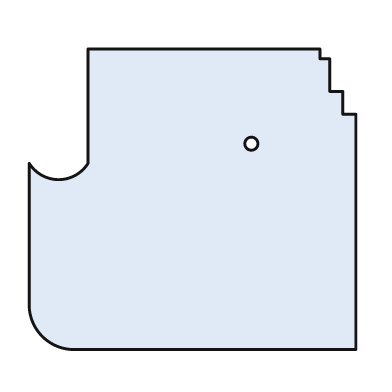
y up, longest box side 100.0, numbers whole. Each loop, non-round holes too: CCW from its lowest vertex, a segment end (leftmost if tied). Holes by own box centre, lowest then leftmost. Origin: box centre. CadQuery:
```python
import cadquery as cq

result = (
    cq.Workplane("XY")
    .moveTo(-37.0, -46.0)
    .lineTo(50.0, -46.0)
    .lineTo(50.0, 26.0)
    .lineTo(46.0, 26.0)
    .lineTo(46.0, 33.0)
    .lineTo(42.0, 33.0)
    .lineTo(42.0, 43.0)
    .lineTo(39.0, 43.0)
    .lineTo(39.0, 46.0)
    .lineTo(-32.0, 46.0)
    .lineTo(-32.0, 11.0)
    .threePointArc((-41.0, 6.0), (-50.0, 11.0))
    .lineTo(-50.0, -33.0)
    .threePointArc((-46.0, -42.0), (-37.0, -46.0))
    .close()
    .moveTo(18.0, 17.0)
    .circle(2.0)
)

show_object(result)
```